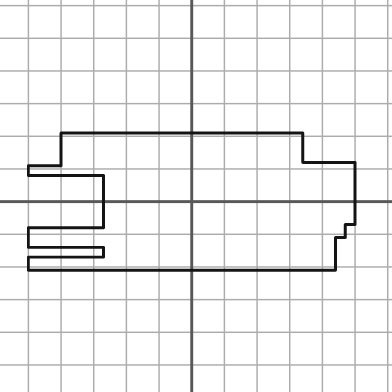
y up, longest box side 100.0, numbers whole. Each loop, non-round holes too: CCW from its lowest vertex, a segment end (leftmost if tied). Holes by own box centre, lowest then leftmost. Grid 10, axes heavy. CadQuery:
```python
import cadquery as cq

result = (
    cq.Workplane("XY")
    .moveTo(-50.0, -21.0)
    .lineTo(44.0, -21.0)
    .lineTo(44.0, -11.0)
    .lineTo(47.0, -11.0)
    .lineTo(47.0, -7.0)
    .lineTo(50.0, -7.0)
    .lineTo(50.0, 12.0)
    .lineTo(34.0, 12.0)
    .lineTo(34.0, 21.0)
    .lineTo(-40.0, 21.0)
    .lineTo(-40.0, 11.0)
    .lineTo(-50.0, 11.0)
    .lineTo(-50.0, 8.0)
    .lineTo(-27.0, 8.0)
    .lineTo(-27.0, -8.0)
    .lineTo(-50.0, -8.0)
    .lineTo(-50.0, -14.0)
    .lineTo(-27.0, -14.0)
    .lineTo(-27.0, -17.0)
    .lineTo(-50.0, -17.0)
    .close()
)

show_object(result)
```